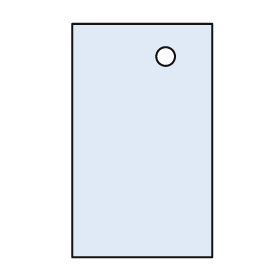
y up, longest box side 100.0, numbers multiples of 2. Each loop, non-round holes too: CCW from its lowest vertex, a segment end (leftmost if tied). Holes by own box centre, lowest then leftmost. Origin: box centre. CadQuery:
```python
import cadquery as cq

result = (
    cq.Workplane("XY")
    .moveTo(-30.0, -50.0)
    .lineTo(30.0, -50.0)
    .lineTo(30.0, 50.0)
    .lineTo(-30.0, 50.0)
    .close()
    .moveTo(10.0, 36.0)
    .circle(4.0)
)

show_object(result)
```